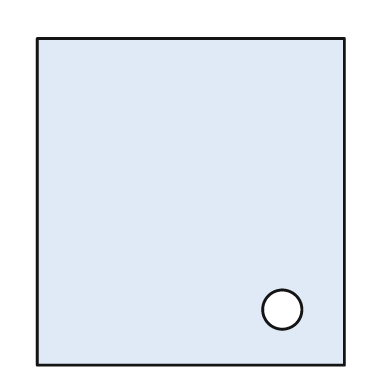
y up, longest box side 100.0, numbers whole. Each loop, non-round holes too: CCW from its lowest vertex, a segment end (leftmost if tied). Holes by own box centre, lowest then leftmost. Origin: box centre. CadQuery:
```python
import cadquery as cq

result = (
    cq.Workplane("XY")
    .moveTo(-47.0, -50.0)
    .lineTo(47.0, -50.0)
    .lineTo(47.0, 50.0)
    .lineTo(-47.0, 50.0)
    .close()
    .moveTo(28.0, -33.0)
    .circle(6.0)
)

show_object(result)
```